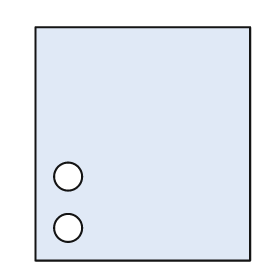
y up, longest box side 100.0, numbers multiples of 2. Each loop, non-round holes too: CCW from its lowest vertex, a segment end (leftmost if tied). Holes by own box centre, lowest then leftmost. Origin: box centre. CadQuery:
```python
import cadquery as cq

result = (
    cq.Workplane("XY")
    .moveTo(-46.0, -50.0)
    .lineTo(46.0, -50.0)
    .lineTo(46.0, 50.0)
    .lineTo(-46.0, 50.0)
    .close()
    .moveTo(-32.0, -36.0)
    .circle(6.0)
    .moveTo(-32.0, -14.0)
    .circle(6.0)
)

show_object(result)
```